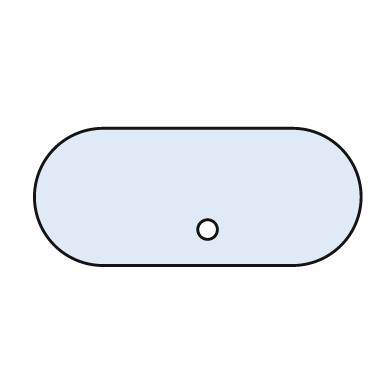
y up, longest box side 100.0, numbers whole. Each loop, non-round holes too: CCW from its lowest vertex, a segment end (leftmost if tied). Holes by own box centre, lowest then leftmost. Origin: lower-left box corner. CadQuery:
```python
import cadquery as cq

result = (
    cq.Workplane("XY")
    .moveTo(21.0, 0.0)
    .lineTo(79.0, 0.0)
    .threePointArc((100.0, 21.0), (79.0, 42.0))
    .lineTo(21.0, 42.0)
    .threePointArc((0.0, 21.0), (21.0, 0.0))
    .close()
    .moveTo(53.0, 11.0)
    .circle(3.0)
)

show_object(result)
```